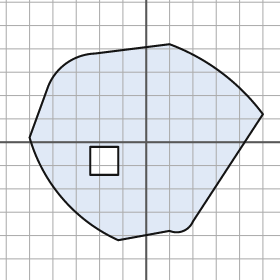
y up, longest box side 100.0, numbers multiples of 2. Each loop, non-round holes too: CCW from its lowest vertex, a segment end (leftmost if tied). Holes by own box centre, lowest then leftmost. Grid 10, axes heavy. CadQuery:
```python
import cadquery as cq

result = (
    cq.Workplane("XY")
    .moveTo(-12.0, -42.0)
    .lineTo(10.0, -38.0)
    .threePointArc((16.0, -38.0), (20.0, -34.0))
    .lineTo(50.0, 12.0)
    .threePointArc((32.0, 30.0), (10.0, 42.0))
    .lineTo(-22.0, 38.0)
    .threePointArc((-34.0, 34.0), (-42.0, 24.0))
    .lineTo(-50.0, 2.0)
    .threePointArc((-36.0, -24.0), (-12.0, -42.0))
    .close()
    .moveTo(-24.0, -14.0)
    .lineTo(-12.0, -14.0)
    .lineTo(-12.0, -2.0)
    .lineTo(-24.0, -2.0)
    .close()
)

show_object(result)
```